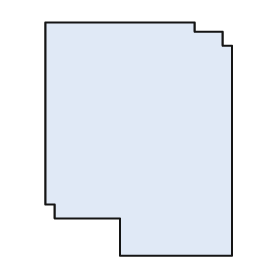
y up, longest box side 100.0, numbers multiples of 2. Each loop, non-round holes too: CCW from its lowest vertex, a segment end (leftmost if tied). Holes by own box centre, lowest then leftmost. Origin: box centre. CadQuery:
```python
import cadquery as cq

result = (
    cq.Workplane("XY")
    .moveTo(-8.0, -50.0)
    .lineTo(40.0, -50.0)
    .lineTo(40.0, 40.0)
    .lineTo(36.0, 40.0)
    .lineTo(36.0, 46.0)
    .lineTo(24.0, 46.0)
    .lineTo(24.0, 50.0)
    .lineTo(-40.0, 50.0)
    .lineTo(-40.0, -28.0)
    .lineTo(-36.0, -28.0)
    .lineTo(-36.0, -34.0)
    .lineTo(-8.0, -34.0)
    .close()
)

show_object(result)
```